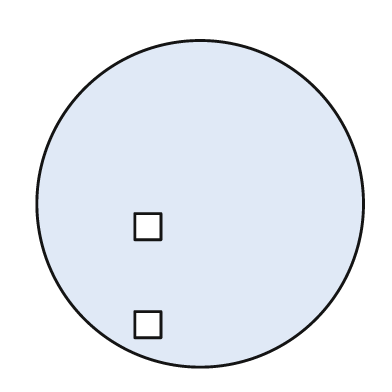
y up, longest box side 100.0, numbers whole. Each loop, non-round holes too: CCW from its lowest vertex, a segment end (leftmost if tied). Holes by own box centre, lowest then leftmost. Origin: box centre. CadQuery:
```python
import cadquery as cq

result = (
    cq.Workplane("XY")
    .moveTo(0.0, 0.0)
    .circle(50.0)
    .moveTo(-20.0, -41.0)
    .lineTo(-12.0, -41.0)
    .lineTo(-12.0, -33.0)
    .lineTo(-20.0, -33.0)
    .close()
    .moveTo(-20.0, -11.0)
    .lineTo(-12.0, -11.0)
    .lineTo(-12.0, -3.0)
    .lineTo(-20.0, -3.0)
    .close()
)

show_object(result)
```